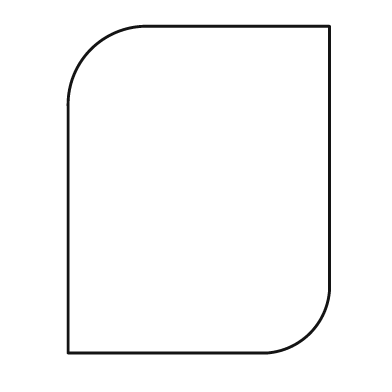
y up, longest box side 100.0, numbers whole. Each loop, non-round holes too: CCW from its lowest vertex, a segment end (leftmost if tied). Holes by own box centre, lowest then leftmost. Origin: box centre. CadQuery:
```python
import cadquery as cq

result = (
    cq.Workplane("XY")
    .moveTo(-40.0, -50.0)
    .lineTo(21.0, -50.0)
    .threePointArc((34.0, -44.0), (40.0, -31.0))
    .lineTo(40.0, 50.0)
    .lineTo(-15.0, 50.0)
    .threePointArc((-33.0, 43.0), (-40.0, 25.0))
    .close()
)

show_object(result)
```